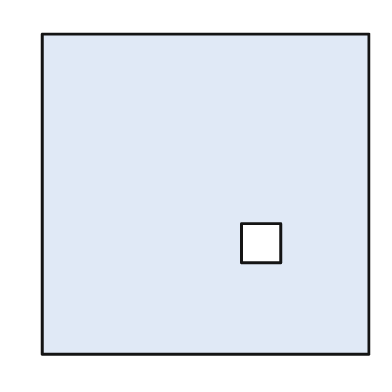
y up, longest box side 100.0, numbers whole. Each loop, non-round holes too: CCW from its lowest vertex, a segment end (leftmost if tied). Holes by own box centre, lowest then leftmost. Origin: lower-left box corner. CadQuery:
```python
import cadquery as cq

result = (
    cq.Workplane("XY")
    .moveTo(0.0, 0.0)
    .lineTo(100.0, 0.0)
    .lineTo(100.0, 98.0)
    .lineTo(0.0, 98.0)
    .close()
    .moveTo(61.0, 28.0)
    .lineTo(73.0, 28.0)
    .lineTo(73.0, 40.0)
    .lineTo(61.0, 40.0)
    .close()
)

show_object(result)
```